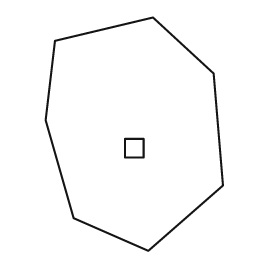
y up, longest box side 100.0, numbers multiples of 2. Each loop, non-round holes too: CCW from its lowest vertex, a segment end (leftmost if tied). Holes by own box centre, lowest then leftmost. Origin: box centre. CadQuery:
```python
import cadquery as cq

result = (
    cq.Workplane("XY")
    .moveTo(6.0, -50.0)
    .lineTo(38.0, -22.0)
    .lineTo(34.0, 26.0)
    .lineTo(8.0, 50.0)
    .lineTo(-34.0, 40.0)
    .lineTo(-38.0, 6.0)
    .lineTo(-26.0, -36.0)
    .close()
    .moveTo(-4.0, -10.0)
    .lineTo(4.0, -10.0)
    .lineTo(4.0, -2.0)
    .lineTo(-4.0, -2.0)
    .close()
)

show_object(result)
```